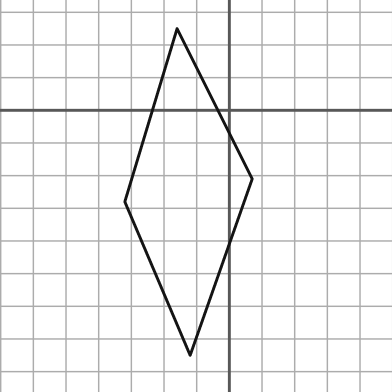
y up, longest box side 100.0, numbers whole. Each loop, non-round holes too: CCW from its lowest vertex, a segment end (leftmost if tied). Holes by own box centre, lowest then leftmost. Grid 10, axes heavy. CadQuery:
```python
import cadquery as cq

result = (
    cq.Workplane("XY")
    .moveTo(-12.0, -75.0)
    .lineTo(7.0, -21.0)
    .lineTo(-16.0, 25.0)
    .lineTo(-32.0, -28.0)
    .close()
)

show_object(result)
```